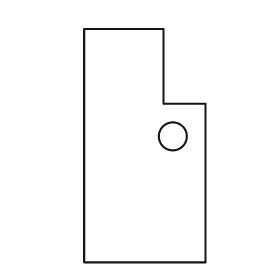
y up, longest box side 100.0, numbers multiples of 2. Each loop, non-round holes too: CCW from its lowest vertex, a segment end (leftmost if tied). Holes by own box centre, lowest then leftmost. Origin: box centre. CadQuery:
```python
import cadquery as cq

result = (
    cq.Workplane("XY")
    .moveTo(-26.0, -50.0)
    .lineTo(26.0, -50.0)
    .lineTo(26.0, 18.0)
    .lineTo(8.0, 18.0)
    .lineTo(8.0, 50.0)
    .lineTo(-26.0, 50.0)
    .close()
    .moveTo(12.0, 4.0)
    .circle(6.0)
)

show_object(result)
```